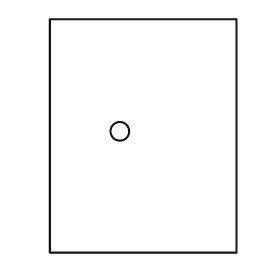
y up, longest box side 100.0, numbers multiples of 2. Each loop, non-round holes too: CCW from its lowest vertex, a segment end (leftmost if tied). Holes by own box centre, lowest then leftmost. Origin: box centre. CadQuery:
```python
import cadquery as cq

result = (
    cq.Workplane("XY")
    .moveTo(-40.0, -50.0)
    .lineTo(40.0, -50.0)
    .lineTo(40.0, 50.0)
    .lineTo(-40.0, 50.0)
    .close()
    .moveTo(-10.0, 2.0)
    .circle(4.0)
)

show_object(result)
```